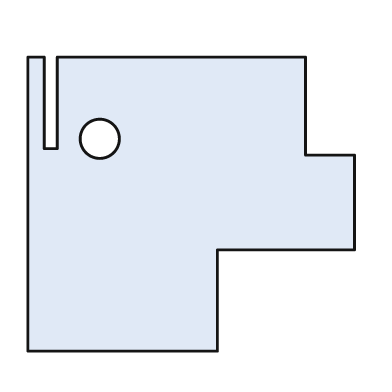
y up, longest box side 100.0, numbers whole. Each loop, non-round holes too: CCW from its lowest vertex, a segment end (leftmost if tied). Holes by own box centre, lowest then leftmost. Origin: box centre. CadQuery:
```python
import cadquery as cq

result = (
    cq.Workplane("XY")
    .moveTo(-50.0, -45.0)
    .lineTo(8.0, -45.0)
    .lineTo(8.0, -14.0)
    .lineTo(50.0, -14.0)
    .lineTo(50.0, 15.0)
    .lineTo(35.0, 15.0)
    .lineTo(35.0, 45.0)
    .lineTo(-41.0, 45.0)
    .lineTo(-41.0, 17.0)
    .lineTo(-45.0, 17.0)
    .lineTo(-45.0, 45.0)
    .lineTo(-50.0, 45.0)
    .close()
    .moveTo(-28.0, 20.0)
    .circle(6.0)
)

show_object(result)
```